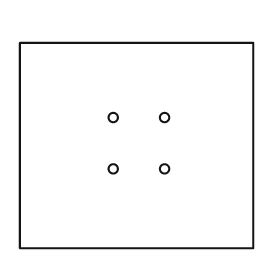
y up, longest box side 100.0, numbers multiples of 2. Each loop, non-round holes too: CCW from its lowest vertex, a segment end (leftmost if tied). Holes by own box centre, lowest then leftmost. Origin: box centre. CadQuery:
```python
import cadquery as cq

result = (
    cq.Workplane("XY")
    .moveTo(-50.0, -44.0)
    .lineTo(50.0, -44.0)
    .lineTo(50.0, 44.0)
    .lineTo(-50.0, 44.0)
    .close()
    .moveTo(-10.0, -10.0)
    .circle(2.0)
    .moveTo(12.0, -10.0)
    .circle(2.0)
    .moveTo(-10.0, 12.0)
    .circle(2.0)
    .moveTo(12.0, 12.0)
    .circle(2.0)
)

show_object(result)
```